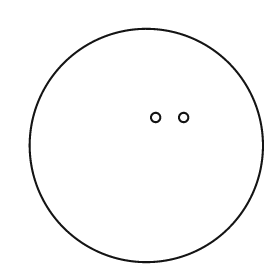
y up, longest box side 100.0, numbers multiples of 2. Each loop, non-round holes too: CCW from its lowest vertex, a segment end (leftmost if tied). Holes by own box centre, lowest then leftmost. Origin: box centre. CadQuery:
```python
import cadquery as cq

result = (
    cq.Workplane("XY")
    .moveTo(0.0, 0.0)
    .circle(50.0)
    .moveTo(4.0, 12.0)
    .circle(2.0)
    .moveTo(16.0, 12.0)
    .circle(2.0)
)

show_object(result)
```